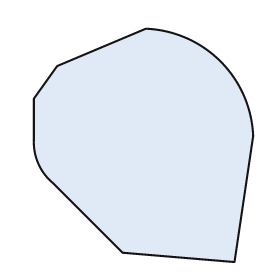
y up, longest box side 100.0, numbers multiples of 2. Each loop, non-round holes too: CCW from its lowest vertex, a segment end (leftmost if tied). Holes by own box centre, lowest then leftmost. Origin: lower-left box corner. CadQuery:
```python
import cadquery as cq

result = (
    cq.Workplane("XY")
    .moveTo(86.0, 0.0)
    .lineTo(94.0, 54.0)
    .threePointArc((80.0, 86.0), (48.0, 100.0))
    .lineTo(10.0, 84.0)
    .lineTo(0.0, 70.0)
    .lineTo(0.0, 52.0)
    .threePointArc((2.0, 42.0), (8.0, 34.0))
    .lineTo(38.0, 4.0)
    .close()
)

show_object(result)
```